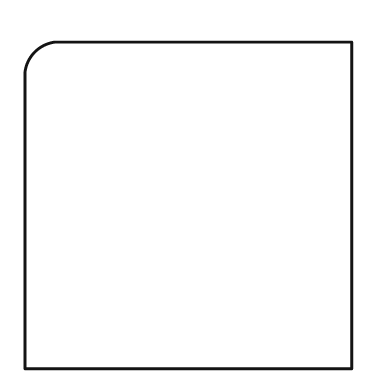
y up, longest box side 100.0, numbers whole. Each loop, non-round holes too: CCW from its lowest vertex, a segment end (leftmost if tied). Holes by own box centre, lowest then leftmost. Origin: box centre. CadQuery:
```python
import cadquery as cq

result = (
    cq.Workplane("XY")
    .moveTo(-50.0, -50.0)
    .lineTo(50.0, -50.0)
    .lineTo(50.0, 50.0)
    .lineTo(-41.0, 50.0)
    .threePointArc((-47.0, 47.0), (-50.0, 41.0))
    .close()
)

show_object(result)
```